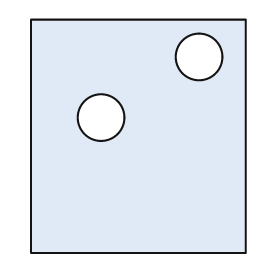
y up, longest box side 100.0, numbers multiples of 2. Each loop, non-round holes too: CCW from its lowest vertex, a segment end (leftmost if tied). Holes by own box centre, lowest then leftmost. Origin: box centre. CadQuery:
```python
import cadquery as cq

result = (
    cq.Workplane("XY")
    .moveTo(-46.0, -50.0)
    .lineTo(46.0, -50.0)
    .lineTo(46.0, 50.0)
    .lineTo(-46.0, 50.0)
    .close()
    .moveTo(-16.0, 8.0)
    .circle(10.0)
    .moveTo(26.0, 34.0)
    .circle(10.0)
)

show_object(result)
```